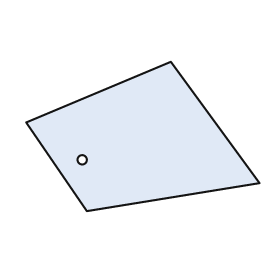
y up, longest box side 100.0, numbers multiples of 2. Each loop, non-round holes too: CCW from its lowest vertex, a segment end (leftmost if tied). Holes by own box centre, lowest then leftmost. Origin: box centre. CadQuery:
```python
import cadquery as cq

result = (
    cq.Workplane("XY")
    .moveTo(-24.0, -32.0)
    .lineTo(50.0, -20.0)
    .lineTo(12.0, 32.0)
    .lineTo(-50.0, 6.0)
    .close()
    .moveTo(-26.0, -10.0)
    .circle(2.0)
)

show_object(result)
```